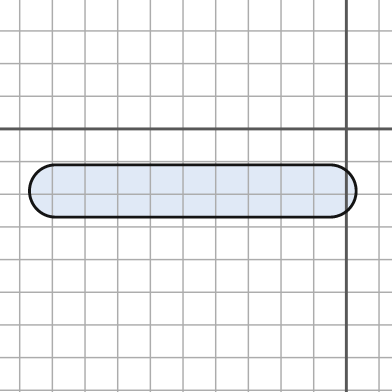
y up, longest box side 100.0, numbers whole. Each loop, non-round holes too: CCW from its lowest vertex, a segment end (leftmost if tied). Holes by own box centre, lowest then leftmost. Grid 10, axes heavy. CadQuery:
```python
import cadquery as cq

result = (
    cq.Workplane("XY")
    .moveTo(-89.0, -27.0)
    .lineTo(-5.0, -27.0)
    .threePointArc((3.0, -19.0), (-5.0, -11.0))
    .lineTo(-89.0, -11.0)
    .threePointArc((-97.0, -19.0), (-89.0, -27.0))
    .close()
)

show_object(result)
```